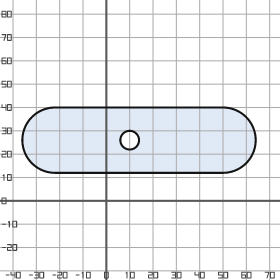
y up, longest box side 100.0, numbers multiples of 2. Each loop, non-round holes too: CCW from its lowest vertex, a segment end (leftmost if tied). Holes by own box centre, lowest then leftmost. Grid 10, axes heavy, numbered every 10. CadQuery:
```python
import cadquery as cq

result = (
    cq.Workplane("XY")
    .moveTo(-22.0, 12.0)
    .lineTo(50.0, 12.0)
    .threePointArc((64.0, 26.0), (50.0, 40.0))
    .lineTo(-22.0, 40.0)
    .threePointArc((-36.0, 26.0), (-22.0, 12.0))
    .close()
    .moveTo(10.0, 26.0)
    .circle(4.0)
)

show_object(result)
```